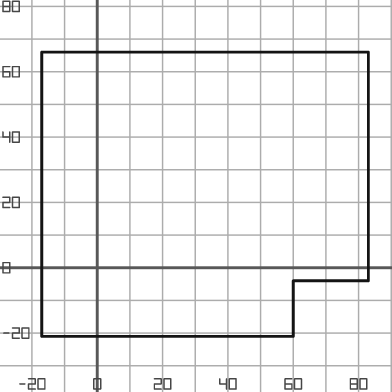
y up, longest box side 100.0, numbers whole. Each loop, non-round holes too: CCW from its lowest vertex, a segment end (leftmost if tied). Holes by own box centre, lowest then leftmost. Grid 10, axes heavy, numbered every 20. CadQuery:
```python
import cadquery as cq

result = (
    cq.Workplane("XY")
    .moveTo(-17.0, -21.0)
    .lineTo(60.0, -21.0)
    .lineTo(60.0, -4.0)
    .lineTo(83.0, -4.0)
    .lineTo(83.0, 66.0)
    .lineTo(-17.0, 66.0)
    .close()
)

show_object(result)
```